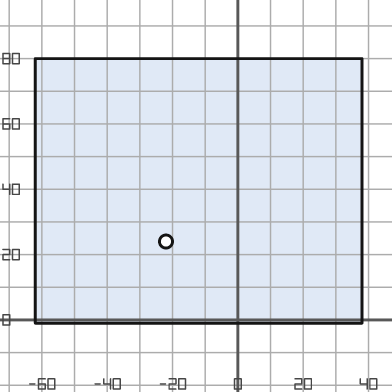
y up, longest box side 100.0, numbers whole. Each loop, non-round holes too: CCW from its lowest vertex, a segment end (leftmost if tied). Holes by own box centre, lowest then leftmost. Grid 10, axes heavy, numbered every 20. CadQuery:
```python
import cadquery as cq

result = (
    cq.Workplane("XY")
    .moveTo(-62.0, -1.0)
    .lineTo(38.0, -1.0)
    .lineTo(38.0, 80.0)
    .lineTo(-62.0, 80.0)
    .close()
    .moveTo(-22.0, 24.0)
    .circle(2.0)
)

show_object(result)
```